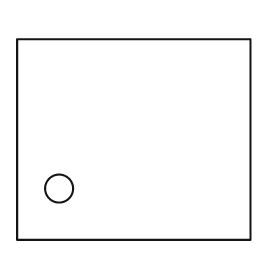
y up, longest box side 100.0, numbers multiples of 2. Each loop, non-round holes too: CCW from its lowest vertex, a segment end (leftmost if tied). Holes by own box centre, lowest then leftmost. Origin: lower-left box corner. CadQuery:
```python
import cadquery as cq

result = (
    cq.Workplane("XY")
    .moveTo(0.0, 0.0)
    .lineTo(100.0, 0.0)
    .lineTo(100.0, 86.0)
    .lineTo(0.0, 86.0)
    .close()
    .moveTo(18.0, 22.0)
    .circle(6.0)
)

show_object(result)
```